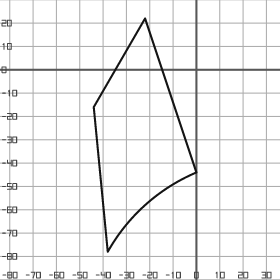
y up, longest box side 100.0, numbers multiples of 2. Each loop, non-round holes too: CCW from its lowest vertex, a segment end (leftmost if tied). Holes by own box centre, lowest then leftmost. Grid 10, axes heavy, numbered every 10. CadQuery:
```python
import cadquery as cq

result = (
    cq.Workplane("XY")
    .moveTo(-38.0, -78.0)
    .threePointArc((-22.0, -58.0), (0.0, -44.0))
    .lineTo(-22.0, 22.0)
    .lineTo(-44.0, -16.0)
    .close()
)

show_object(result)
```